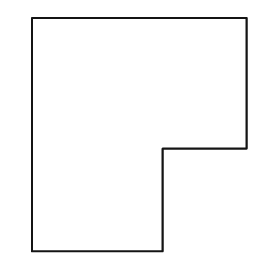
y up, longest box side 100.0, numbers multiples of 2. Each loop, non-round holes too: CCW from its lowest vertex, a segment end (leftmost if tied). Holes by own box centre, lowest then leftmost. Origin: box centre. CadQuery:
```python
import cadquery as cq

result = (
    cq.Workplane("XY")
    .moveTo(-46.0, -50.0)
    .lineTo(10.0, -50.0)
    .lineTo(10.0, -6.0)
    .lineTo(46.0, -6.0)
    .lineTo(46.0, 50.0)
    .lineTo(-46.0, 50.0)
    .close()
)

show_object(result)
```